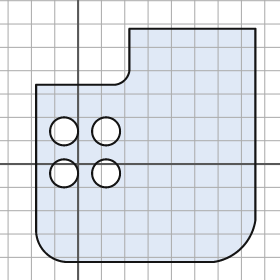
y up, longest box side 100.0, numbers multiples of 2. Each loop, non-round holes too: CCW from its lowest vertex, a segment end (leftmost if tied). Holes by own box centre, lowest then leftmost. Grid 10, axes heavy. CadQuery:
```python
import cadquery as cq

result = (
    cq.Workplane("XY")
    .moveTo(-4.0, -42.0)
    .lineTo(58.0, -42.0)
    .threePointArc((70.0, -36.0), (76.0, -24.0))
    .lineTo(76.0, 58.0)
    .lineTo(22.0, 58.0)
    .lineTo(22.0, 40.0)
    .threePointArc((20.0, 36.0), (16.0, 34.0))
    .lineTo(-18.0, 34.0)
    .lineTo(-18.0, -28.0)
    .threePointArc((-14.0, -38.0), (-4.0, -42.0))
    .close()
    .moveTo(-6.0, -4.0)
    .circle(6.0)
    .moveTo(12.0, -4.0)
    .circle(6.0)
    .moveTo(-6.0, 14.0)
    .circle(6.0)
    .moveTo(12.0, 14.0)
    .circle(6.0)
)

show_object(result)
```